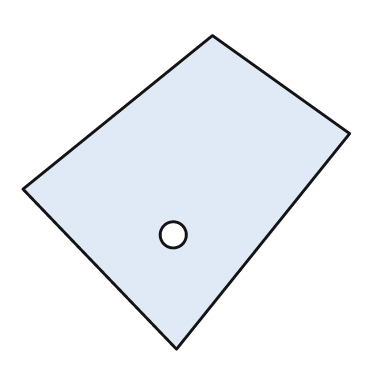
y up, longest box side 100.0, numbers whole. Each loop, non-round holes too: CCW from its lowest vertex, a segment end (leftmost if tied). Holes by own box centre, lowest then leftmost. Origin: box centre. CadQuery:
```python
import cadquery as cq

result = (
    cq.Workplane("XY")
    .moveTo(-3.0, -48.0)
    .lineTo(50.0, 18.0)
    .lineTo(8.0, 48.0)
    .lineTo(-50.0, 1.0)
    .close()
    .moveTo(-4.0, -13.0)
    .circle(4.0)
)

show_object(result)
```